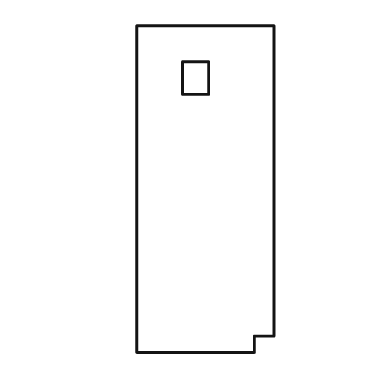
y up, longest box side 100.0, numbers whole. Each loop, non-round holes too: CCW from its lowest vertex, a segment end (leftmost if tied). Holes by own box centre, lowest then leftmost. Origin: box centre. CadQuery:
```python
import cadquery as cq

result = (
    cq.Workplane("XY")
    .moveTo(-21.0, -50.0)
    .lineTo(15.0, -50.0)
    .lineTo(15.0, -45.0)
    .lineTo(21.0, -45.0)
    .lineTo(21.0, 50.0)
    .lineTo(-21.0, 50.0)
    .close()
    .moveTo(-7.0, 29.0)
    .lineTo(1.0, 29.0)
    .lineTo(1.0, 39.0)
    .lineTo(-7.0, 39.0)
    .close()
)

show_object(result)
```